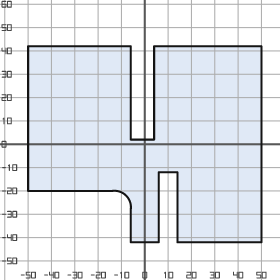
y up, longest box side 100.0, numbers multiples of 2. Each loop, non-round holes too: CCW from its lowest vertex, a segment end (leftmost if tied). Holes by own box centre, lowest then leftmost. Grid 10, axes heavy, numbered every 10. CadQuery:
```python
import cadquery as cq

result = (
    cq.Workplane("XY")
    .moveTo(-6.0, -42.0)
    .lineTo(6.0, -42.0)
    .lineTo(6.0, -12.0)
    .lineTo(14.0, -12.0)
    .lineTo(14.0, -42.0)
    .lineTo(50.0, -42.0)
    .lineTo(50.0, 42.0)
    .lineTo(4.0, 42.0)
    .lineTo(4.0, 2.0)
    .lineTo(-6.0, 2.0)
    .lineTo(-6.0, 42.0)
    .lineTo(-50.0, 42.0)
    .lineTo(-50.0, -20.0)
    .lineTo(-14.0, -20.0)
    .threePointArc((-8.0, -22.0), (-6.0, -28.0))
    .close()
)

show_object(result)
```